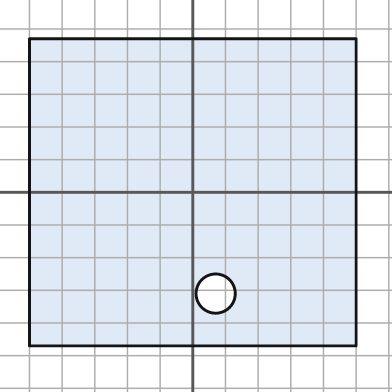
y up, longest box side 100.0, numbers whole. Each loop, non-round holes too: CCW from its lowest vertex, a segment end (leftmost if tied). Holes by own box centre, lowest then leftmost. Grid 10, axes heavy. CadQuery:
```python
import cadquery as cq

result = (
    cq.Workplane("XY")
    .moveTo(-50.0, -47.0)
    .lineTo(50.0, -47.0)
    .lineTo(50.0, 47.0)
    .lineTo(-50.0, 47.0)
    .close()
    .moveTo(7.0, -31.0)
    .circle(6.0)
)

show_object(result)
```